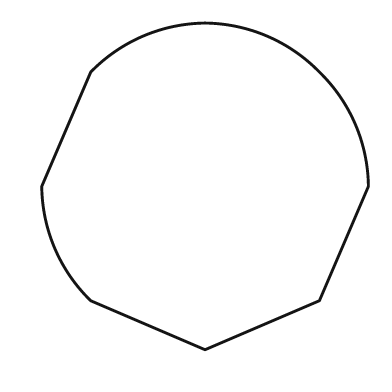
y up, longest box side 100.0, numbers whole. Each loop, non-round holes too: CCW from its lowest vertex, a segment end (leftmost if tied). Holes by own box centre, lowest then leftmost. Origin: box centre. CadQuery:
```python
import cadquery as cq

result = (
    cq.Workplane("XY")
    .moveTo(0.0, -50.0)
    .lineTo(35.0, -35.0)
    .lineTo(50.0, 0.0)
    .threePointArc((46.0, 19.0), (35.0, 35.0))
    .threePointArc((19.0, 46.0), (0.0, 50.0))
    .threePointArc((-19.0, 46.0), (-35.0, 35.0))
    .lineTo(-50.0, 0.0)
    .threePointArc((-46.0, -19.0), (-35.0, -35.0))
    .close()
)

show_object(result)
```